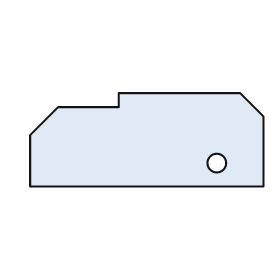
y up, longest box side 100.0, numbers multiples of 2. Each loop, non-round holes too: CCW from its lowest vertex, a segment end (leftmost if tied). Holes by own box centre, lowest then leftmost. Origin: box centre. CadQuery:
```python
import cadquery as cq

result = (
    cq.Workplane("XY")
    .moveTo(-50.0, -20.0)
    .lineTo(50.0, -20.0)
    .lineTo(50.0, 10.0)
    .lineTo(40.0, 20.0)
    .lineTo(-12.0, 20.0)
    .lineTo(-12.0, 14.0)
    .lineTo(-38.0, 14.0)
    .lineTo(-50.0, 2.0)
    .close()
    .moveTo(30.0, -10.0)
    .circle(4.0)
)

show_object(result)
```